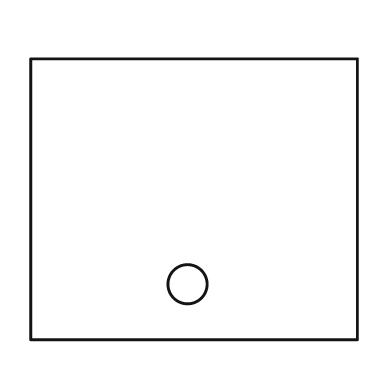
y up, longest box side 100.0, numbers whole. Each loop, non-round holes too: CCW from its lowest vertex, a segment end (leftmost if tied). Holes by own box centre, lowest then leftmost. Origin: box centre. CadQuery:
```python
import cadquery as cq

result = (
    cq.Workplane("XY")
    .moveTo(-50.0, -43.0)
    .lineTo(50.0, -43.0)
    .lineTo(50.0, 43.0)
    .lineTo(-50.0, 43.0)
    .close()
    .moveTo(-2.0, -26.0)
    .circle(6.0)
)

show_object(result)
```